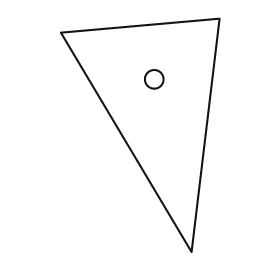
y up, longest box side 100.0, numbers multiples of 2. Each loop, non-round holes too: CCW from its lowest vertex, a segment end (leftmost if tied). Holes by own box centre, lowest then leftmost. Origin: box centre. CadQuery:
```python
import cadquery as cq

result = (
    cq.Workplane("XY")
    .moveTo(22.0, -50.0)
    .lineTo(34.0, 50.0)
    .lineTo(-34.0, 44.0)
    .close()
    .moveTo(6.0, 24.0)
    .circle(4.0)
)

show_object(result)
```